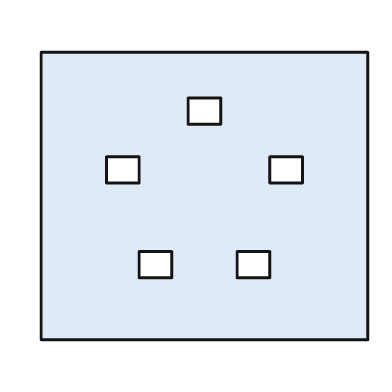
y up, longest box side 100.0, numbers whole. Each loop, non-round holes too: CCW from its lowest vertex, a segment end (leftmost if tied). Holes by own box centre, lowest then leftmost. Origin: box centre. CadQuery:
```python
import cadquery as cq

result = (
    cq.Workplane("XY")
    .moveTo(-50.0, -44.0)
    .lineTo(50.0, -44.0)
    .lineTo(50.0, 44.0)
    .lineTo(-50.0, 44.0)
    .close()
    .moveTo(-20.0, -25.0)
    .lineTo(-10.0, -25.0)
    .lineTo(-10.0, -17.0)
    .lineTo(-20.0, -17.0)
    .close()
    .moveTo(10.0, -25.0)
    .lineTo(20.0, -25.0)
    .lineTo(20.0, -17.0)
    .lineTo(10.0, -17.0)
    .close()
    .moveTo(-30.0, 4.0)
    .lineTo(-20.0, 4.0)
    .lineTo(-20.0, 12.0)
    .lineTo(-30.0, 12.0)
    .close()
    .moveTo(20.0, 4.0)
    .lineTo(30.0, 4.0)
    .lineTo(30.0, 12.0)
    .lineTo(20.0, 12.0)
    .close()
    .moveTo(-5.0, 22.0)
    .lineTo(5.0, 22.0)
    .lineTo(5.0, 30.0)
    .lineTo(-5.0, 30.0)
    .close()
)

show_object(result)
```